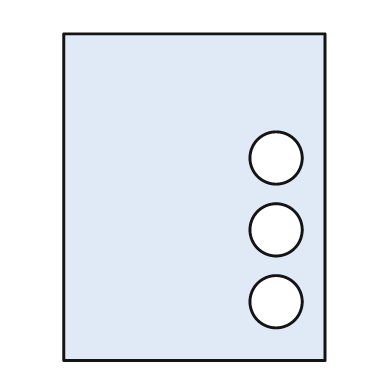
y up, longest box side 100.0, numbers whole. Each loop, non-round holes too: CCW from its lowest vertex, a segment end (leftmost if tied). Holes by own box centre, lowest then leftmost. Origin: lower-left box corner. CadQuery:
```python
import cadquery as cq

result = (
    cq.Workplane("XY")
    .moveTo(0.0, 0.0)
    .lineTo(80.0, 0.0)
    .lineTo(80.0, 100.0)
    .lineTo(0.0, 100.0)
    .close()
    .moveTo(65.0, 18.0)
    .circle(8.0)
    .moveTo(65.0, 40.0)
    .circle(8.0)
    .moveTo(65.0, 62.0)
    .circle(8.0)
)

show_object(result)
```